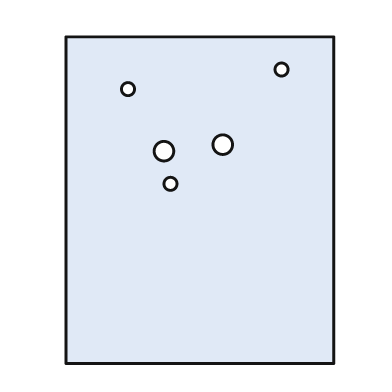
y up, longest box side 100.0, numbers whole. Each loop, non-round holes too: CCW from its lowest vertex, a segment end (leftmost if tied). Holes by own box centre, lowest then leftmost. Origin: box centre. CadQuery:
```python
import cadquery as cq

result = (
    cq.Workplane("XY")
    .moveTo(-41.0, -50.0)
    .lineTo(41.0, -50.0)
    .lineTo(41.0, 50.0)
    .lineTo(-41.0, 50.0)
    .close()
    .moveTo(-9.0, 5.0)
    .circle(2.0)
    .moveTo(-11.0, 15.0)
    .circle(3.0)
    .moveTo(7.0, 17.0)
    .circle(3.0)
    .moveTo(-22.0, 34.0)
    .circle(2.0)
    .moveTo(25.0, 40.0)
    .circle(2.0)
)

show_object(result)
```